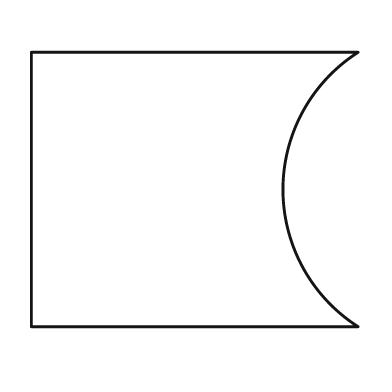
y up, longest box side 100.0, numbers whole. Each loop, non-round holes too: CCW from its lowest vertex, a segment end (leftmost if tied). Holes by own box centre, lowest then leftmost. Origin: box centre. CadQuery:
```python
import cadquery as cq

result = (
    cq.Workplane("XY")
    .moveTo(-50.0, -42.0)
    .lineTo(50.0, -42.0)
    .threePointArc((27.0, 0.0), (50.0, 42.0))
    .lineTo(-50.0, 42.0)
    .close()
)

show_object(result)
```